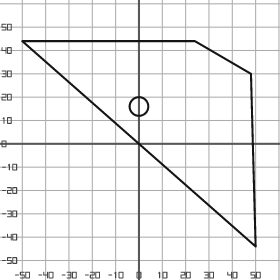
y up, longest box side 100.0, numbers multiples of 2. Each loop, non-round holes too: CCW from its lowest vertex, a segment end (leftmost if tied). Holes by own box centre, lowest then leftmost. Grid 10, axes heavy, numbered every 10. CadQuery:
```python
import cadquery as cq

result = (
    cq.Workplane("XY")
    .moveTo(50.0, -44.0)
    .lineTo(48.0, 30.0)
    .lineTo(24.0, 44.0)
    .lineTo(-50.0, 44.0)
    .close()
    .moveTo(0.0, 16.0)
    .circle(4.0)
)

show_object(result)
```